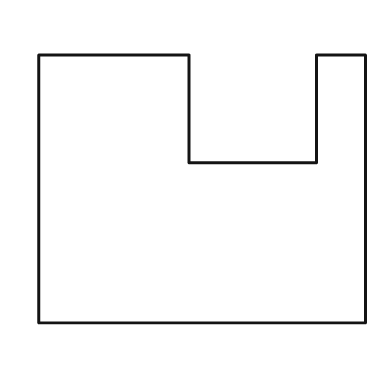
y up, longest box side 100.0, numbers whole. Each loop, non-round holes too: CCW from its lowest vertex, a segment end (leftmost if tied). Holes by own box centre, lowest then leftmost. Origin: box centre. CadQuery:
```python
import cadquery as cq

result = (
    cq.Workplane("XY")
    .moveTo(-50.0, -41.0)
    .lineTo(50.0, -41.0)
    .lineTo(50.0, 41.0)
    .lineTo(35.0, 41.0)
    .lineTo(35.0, 8.0)
    .lineTo(-4.0, 8.0)
    .lineTo(-4.0, 41.0)
    .lineTo(-50.0, 41.0)
    .close()
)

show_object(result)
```